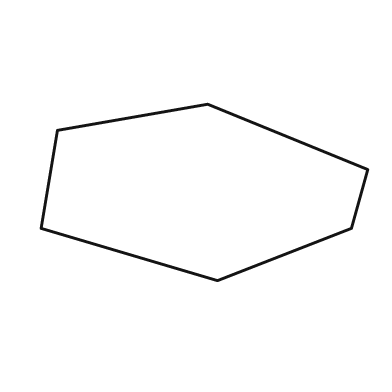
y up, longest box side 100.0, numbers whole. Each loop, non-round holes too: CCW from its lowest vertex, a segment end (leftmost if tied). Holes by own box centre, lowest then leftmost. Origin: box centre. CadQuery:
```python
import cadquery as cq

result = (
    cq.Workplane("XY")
    .moveTo(4.0, -27.0)
    .lineTo(45.0, -11.0)
    .lineTo(50.0, 7.0)
    .lineTo(1.0, 27.0)
    .lineTo(-45.0, 19.0)
    .lineTo(-50.0, -11.0)
    .close()
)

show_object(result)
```